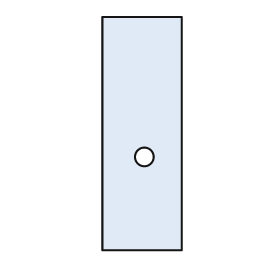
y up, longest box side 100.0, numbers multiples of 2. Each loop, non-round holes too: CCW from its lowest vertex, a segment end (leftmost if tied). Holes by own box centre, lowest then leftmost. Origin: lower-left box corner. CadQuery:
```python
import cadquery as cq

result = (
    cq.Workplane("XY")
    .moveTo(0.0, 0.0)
    .lineTo(34.0, 0.0)
    .lineTo(34.0, 100.0)
    .lineTo(0.0, 100.0)
    .close()
    .moveTo(18.0, 40.0)
    .circle(4.0)
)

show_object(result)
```